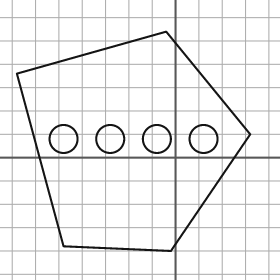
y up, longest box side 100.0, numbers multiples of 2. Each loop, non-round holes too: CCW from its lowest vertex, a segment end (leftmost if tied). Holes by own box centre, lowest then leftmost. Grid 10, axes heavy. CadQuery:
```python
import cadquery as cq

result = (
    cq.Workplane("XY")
    .moveTo(-2.0, -40.0)
    .lineTo(32.0, 10.0)
    .lineTo(-4.0, 54.0)
    .lineTo(-68.0, 36.0)
    .lineTo(-48.0, -38.0)
    .close()
    .moveTo(-48.0, 8.0)
    .circle(6.0)
    .moveTo(-28.0, 8.0)
    .circle(6.0)
    .moveTo(-8.0, 8.0)
    .circle(6.0)
    .moveTo(12.0, 8.0)
    .circle(6.0)
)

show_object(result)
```